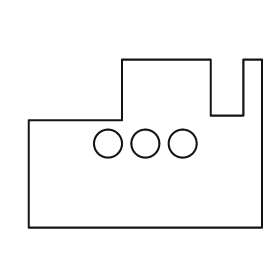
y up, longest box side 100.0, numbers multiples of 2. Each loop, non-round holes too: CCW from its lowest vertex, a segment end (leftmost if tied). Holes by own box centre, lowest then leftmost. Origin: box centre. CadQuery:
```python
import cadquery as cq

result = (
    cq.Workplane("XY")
    .moveTo(-50.0, -36.0)
    .lineTo(50.0, -36.0)
    .lineTo(50.0, 36.0)
    .lineTo(42.0, 36.0)
    .lineTo(42.0, 12.0)
    .lineTo(28.0, 12.0)
    .lineTo(28.0, 36.0)
    .lineTo(-10.0, 36.0)
    .lineTo(-10.0, 10.0)
    .lineTo(-50.0, 10.0)
    .close()
    .moveTo(-16.0, 0.0)
    .circle(6.0)
    .moveTo(0.0, 0.0)
    .circle(6.0)
    .moveTo(16.0, 0.0)
    .circle(6.0)
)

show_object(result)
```